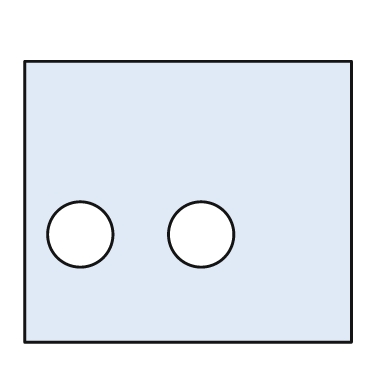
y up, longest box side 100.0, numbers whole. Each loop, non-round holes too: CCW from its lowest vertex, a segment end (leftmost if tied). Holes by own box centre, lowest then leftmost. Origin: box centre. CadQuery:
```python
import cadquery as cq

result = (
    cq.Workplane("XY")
    .moveTo(-50.0, -43.0)
    .lineTo(50.0, -43.0)
    .lineTo(50.0, 43.0)
    .lineTo(-50.0, 43.0)
    .close()
    .moveTo(-33.0, -10.0)
    .circle(10.0)
    .moveTo(4.0, -10.0)
    .circle(10.0)
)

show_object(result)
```